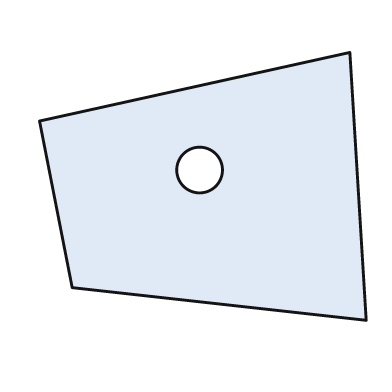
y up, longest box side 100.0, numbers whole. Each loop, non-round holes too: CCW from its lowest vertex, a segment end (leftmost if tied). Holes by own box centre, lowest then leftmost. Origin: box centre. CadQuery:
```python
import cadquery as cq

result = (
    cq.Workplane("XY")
    .moveTo(50.0, -41.0)
    .lineTo(45.0, 41.0)
    .lineTo(-50.0, 20.0)
    .lineTo(-40.0, -31.0)
    .close()
    .moveTo(-1.0, 5.0)
    .circle(7.0)
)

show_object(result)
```